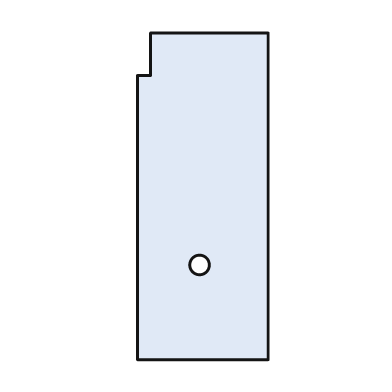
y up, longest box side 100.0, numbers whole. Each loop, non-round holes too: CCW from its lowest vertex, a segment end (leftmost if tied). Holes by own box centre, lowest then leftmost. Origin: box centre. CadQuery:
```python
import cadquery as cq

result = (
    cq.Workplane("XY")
    .moveTo(-20.0, -50.0)
    .lineTo(20.0, -50.0)
    .lineTo(20.0, 50.0)
    .lineTo(-16.0, 50.0)
    .lineTo(-16.0, 37.0)
    .lineTo(-20.0, 37.0)
    .close()
    .moveTo(-1.0, -21.0)
    .circle(3.0)
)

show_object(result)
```